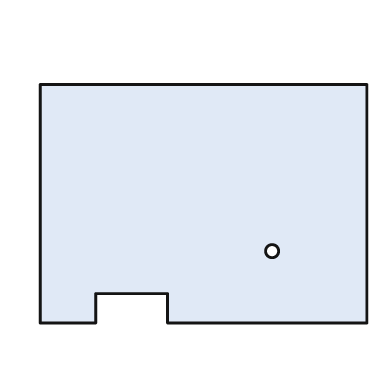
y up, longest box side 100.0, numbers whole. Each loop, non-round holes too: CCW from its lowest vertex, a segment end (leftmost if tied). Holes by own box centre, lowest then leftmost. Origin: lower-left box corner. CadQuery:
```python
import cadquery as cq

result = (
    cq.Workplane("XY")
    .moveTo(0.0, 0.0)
    .lineTo(17.0, 0.0)
    .lineTo(17.0, 9.0)
    .lineTo(39.0, 9.0)
    .lineTo(39.0, 0.0)
    .lineTo(100.0, 0.0)
    .lineTo(100.0, 73.0)
    .lineTo(0.0, 73.0)
    .close()
    .moveTo(71.0, 22.0)
    .circle(2.0)
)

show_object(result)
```